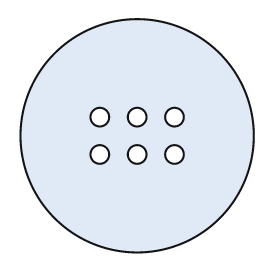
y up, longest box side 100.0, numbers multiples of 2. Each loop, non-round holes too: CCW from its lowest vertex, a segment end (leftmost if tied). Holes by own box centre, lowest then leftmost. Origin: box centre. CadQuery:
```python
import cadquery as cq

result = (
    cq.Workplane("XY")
    .moveTo(0.0, 0.0)
    .circle(50.0)
    .moveTo(-16.0, -8.0)
    .circle(4.0)
    .moveTo(0.0, -8.0)
    .circle(4.0)
    .moveTo(16.0, -8.0)
    .circle(4.0)
    .moveTo(-16.0, 8.0)
    .circle(4.0)
    .moveTo(0.0, 8.0)
    .circle(4.0)
    .moveTo(16.0, 8.0)
    .circle(4.0)
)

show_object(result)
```